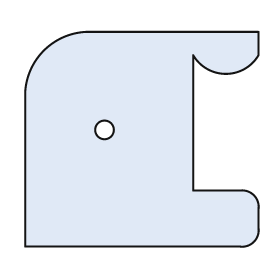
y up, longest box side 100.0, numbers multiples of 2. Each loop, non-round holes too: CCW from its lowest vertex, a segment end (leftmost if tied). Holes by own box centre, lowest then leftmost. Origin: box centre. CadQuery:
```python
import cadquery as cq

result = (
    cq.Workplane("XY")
    .moveTo(-50.0, -46.0)
    .lineTo(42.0, -46.0)
    .threePointArc((48.0, -44.0), (50.0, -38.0))
    .lineTo(50.0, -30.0)
    .threePointArc((48.0, -24.0), (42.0, -22.0))
    .lineTo(22.0, -22.0)
    .lineTo(22.0, 36.0)
    .threePointArc((36.0, 28.0), (50.0, 36.0))
    .lineTo(50.0, 46.0)
    .lineTo(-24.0, 46.0)
    .threePointArc((-42.0, 38.0), (-50.0, 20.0))
    .close()
    .moveTo(-16.0, 4.0)
    .circle(4.0)
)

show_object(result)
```